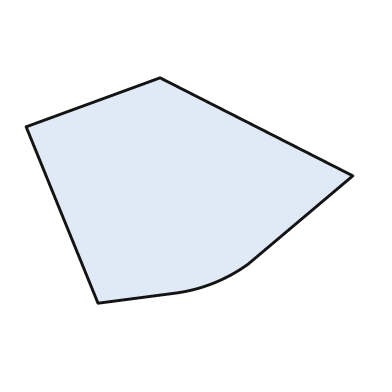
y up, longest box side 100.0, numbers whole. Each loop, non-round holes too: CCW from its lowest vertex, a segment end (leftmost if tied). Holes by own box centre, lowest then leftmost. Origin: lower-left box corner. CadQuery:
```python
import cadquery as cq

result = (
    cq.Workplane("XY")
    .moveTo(22.0, 0.0)
    .lineTo(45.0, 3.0)
    .threePointArc((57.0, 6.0), (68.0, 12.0))
    .lineTo(100.0, 39.0)
    .lineTo(41.0, 69.0)
    .lineTo(0.0, 54.0)
    .close()
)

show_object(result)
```